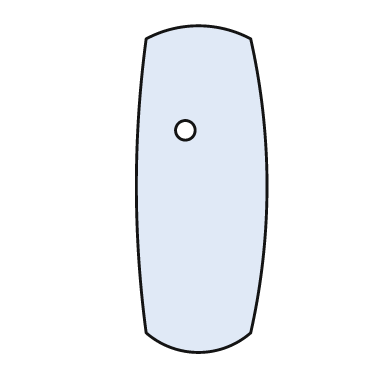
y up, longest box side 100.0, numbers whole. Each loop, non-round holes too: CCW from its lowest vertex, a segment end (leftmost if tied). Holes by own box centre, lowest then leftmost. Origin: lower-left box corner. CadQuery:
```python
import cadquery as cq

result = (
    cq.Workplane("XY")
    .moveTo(3.0, 6.0)
    .threePointArc((19.0, 0.0), (35.0, 6.0))
    .threePointArc((40.0, 51.0), (35.0, 96.0))
    .threePointArc((19.0, 100.0), (3.0, 96.0))
    .threePointArc((0.0, 51.0), (3.0, 6.0))
    .close()
    .moveTo(15.0, 68.0)
    .circle(3.0)
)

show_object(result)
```